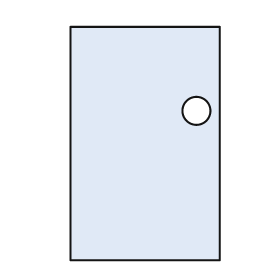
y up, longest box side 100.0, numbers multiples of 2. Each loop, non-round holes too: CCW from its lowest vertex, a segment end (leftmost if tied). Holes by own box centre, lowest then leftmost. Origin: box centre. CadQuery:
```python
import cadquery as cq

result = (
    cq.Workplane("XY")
    .moveTo(-32.0, -50.0)
    .lineTo(32.0, -50.0)
    .lineTo(32.0, 50.0)
    .lineTo(-32.0, 50.0)
    .close()
    .moveTo(22.0, 14.0)
    .circle(6.0)
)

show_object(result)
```